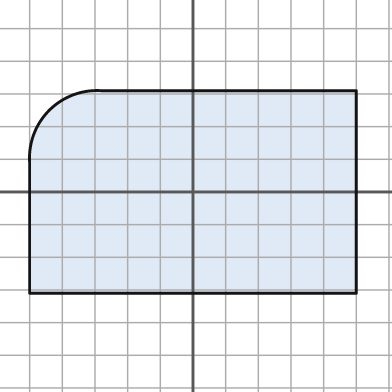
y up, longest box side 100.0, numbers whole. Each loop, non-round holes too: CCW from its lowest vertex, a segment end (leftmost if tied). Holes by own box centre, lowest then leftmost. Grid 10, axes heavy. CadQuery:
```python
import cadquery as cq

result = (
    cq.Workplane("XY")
    .moveTo(-50.0, -31.0)
    .lineTo(50.0, -31.0)
    .lineTo(50.0, 31.0)
    .lineTo(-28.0, 31.0)
    .threePointArc((-44.0, 25.0), (-50.0, 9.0))
    .close()
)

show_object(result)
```